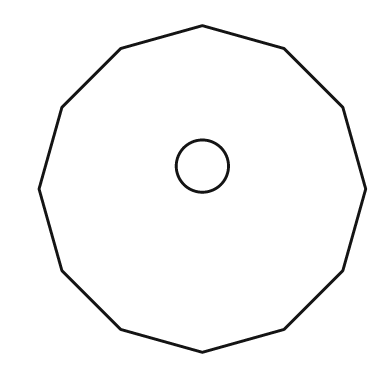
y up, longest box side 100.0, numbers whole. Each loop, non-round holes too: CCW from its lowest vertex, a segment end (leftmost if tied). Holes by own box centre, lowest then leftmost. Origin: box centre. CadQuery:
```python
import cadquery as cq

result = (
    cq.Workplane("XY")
    .moveTo(0.0, -50.0)
    .lineTo(25.0, -43.0)
    .lineTo(43.0, -25.0)
    .lineTo(50.0, 0.0)
    .lineTo(43.0, 25.0)
    .lineTo(25.0, 43.0)
    .lineTo(0.0, 50.0)
    .lineTo(-25.0, 43.0)
    .lineTo(-43.0, 25.0)
    .lineTo(-50.0, 0.0)
    .lineTo(-43.0, -25.0)
    .lineTo(-25.0, -43.0)
    .close()
    .moveTo(0.0, 7.0)
    .circle(8.0)
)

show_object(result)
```